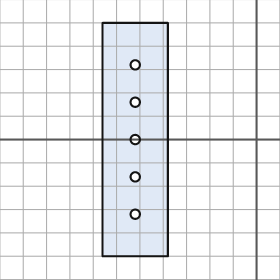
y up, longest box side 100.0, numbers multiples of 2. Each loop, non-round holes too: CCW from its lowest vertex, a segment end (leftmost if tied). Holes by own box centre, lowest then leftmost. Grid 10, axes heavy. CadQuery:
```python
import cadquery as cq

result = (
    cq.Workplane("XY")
    .moveTo(-66.0, -50.0)
    .lineTo(-38.0, -50.0)
    .lineTo(-38.0, 50.0)
    .lineTo(-66.0, 50.0)
    .close()
    .moveTo(-52.0, -32.0)
    .circle(2.0)
    .moveTo(-52.0, -16.0)
    .circle(2.0)
    .moveTo(-52.0, 0.0)
    .circle(2.0)
    .moveTo(-52.0, 16.0)
    .circle(2.0)
    .moveTo(-52.0, 32.0)
    .circle(2.0)
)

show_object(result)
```